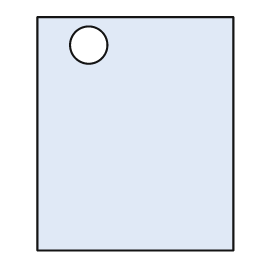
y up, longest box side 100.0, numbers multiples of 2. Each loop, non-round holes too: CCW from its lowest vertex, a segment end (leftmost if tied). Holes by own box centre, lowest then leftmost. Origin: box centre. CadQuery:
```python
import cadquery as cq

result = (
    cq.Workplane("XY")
    .moveTo(-42.0, -50.0)
    .lineTo(42.0, -50.0)
    .lineTo(42.0, 50.0)
    .lineTo(-42.0, 50.0)
    .close()
    .moveTo(-20.0, 38.0)
    .circle(8.0)
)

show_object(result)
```